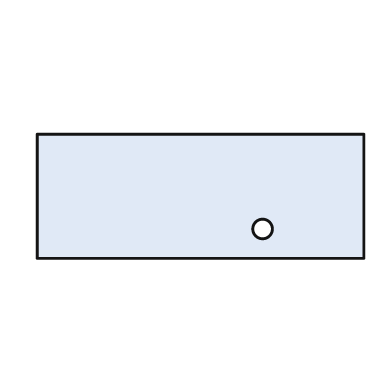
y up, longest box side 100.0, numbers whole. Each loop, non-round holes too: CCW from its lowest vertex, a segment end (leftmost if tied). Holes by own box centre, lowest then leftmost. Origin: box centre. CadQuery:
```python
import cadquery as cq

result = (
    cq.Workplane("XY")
    .moveTo(-50.0, -19.0)
    .lineTo(50.0, -19.0)
    .lineTo(50.0, 19.0)
    .lineTo(-50.0, 19.0)
    .close()
    .moveTo(19.0, -10.0)
    .circle(3.0)
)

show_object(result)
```